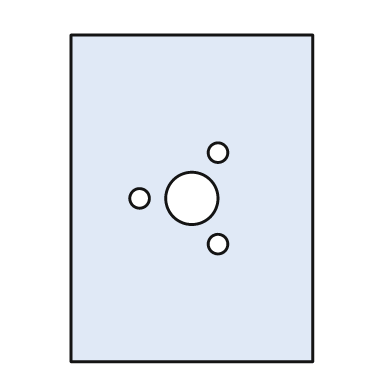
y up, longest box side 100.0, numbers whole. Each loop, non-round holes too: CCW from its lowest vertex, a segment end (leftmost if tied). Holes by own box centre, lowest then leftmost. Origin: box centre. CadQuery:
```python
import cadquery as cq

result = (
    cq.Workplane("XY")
    .moveTo(-37.0, -50.0)
    .lineTo(37.0, -50.0)
    .lineTo(37.0, 50.0)
    .lineTo(-37.0, 50.0)
    .close()
    .moveTo(8.0, -14.0)
    .circle(3.0)
    .moveTo(-16.0, 0.0)
    .circle(3.0)
    .moveTo(0.0, 0.0)
    .circle(8.0)
    .moveTo(8.0, 14.0)
    .circle(3.0)
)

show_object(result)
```